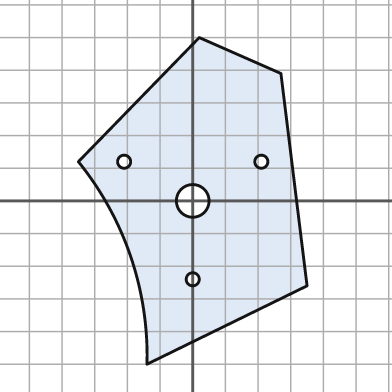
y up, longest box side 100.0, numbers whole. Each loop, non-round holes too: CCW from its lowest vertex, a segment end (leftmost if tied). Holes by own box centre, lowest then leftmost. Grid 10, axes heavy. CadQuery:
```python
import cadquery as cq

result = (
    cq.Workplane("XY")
    .moveTo(-14.0, -50.0)
    .lineTo(35.0, -26.0)
    .lineTo(27.0, 39.0)
    .lineTo(2.0, 50.0)
    .lineTo(-35.0, 12.0)
    .threePointArc((-19.0, -17.0), (-14.0, -50.0))
    .close()
    .moveTo(0.0, -24.0)
    .circle(2.0)
    .moveTo(0.0, 0.0)
    .circle(5.0)
    .moveTo(-21.0, 12.0)
    .circle(2.0)
    .moveTo(21.0, 12.0)
    .circle(2.0)
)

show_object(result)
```